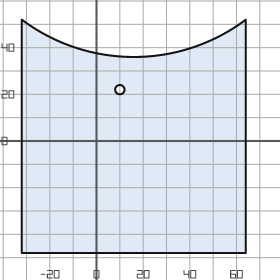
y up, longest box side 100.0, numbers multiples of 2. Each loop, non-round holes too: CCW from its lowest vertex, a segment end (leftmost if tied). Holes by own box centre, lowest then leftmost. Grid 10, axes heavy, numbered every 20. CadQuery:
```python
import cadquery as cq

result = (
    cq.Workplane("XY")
    .moveTo(-32.0, -48.0)
    .lineTo(64.0, -48.0)
    .lineTo(64.0, 52.0)
    .threePointArc((16.0, 36.0), (-32.0, 52.0))
    .close()
    .moveTo(10.0, 22.0)
    .circle(2.0)
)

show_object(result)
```